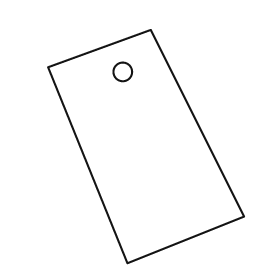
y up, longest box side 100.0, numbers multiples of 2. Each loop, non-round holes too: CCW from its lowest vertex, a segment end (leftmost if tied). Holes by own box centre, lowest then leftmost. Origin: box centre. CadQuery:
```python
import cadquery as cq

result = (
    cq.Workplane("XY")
    .moveTo(-8.0, -50.0)
    .lineTo(42.0, -30.0)
    .lineTo(2.0, 50.0)
    .lineTo(-42.0, 34.0)
    .close()
    .moveTo(-10.0, 32.0)
    .circle(4.0)
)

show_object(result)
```